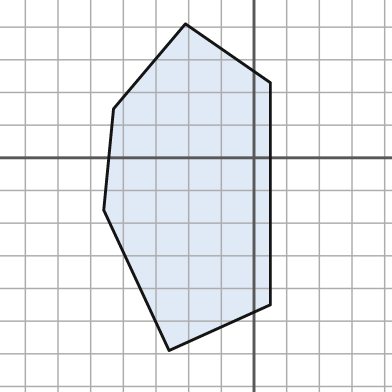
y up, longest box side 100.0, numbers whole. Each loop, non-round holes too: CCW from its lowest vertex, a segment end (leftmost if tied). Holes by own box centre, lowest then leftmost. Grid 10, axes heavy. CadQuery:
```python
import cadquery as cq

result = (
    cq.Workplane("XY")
    .moveTo(-26.0, -59.0)
    .lineTo(5.0, -45.0)
    .lineTo(5.0, 23.0)
    .lineTo(-21.0, 41.0)
    .lineTo(-43.0, 15.0)
    .lineTo(-46.0, -16.0)
    .close()
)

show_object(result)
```